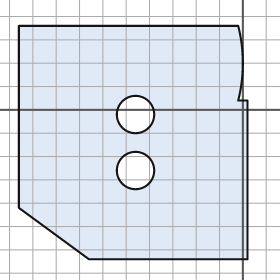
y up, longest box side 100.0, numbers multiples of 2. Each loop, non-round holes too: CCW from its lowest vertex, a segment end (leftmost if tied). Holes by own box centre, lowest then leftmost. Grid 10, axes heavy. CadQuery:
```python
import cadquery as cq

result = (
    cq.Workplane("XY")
    .moveTo(-66.0, -64.0)
    .lineTo(2.0, -64.0)
    .lineTo(2.0, 4.0)
    .lineTo(-2.0, 4.0)
    .threePointArc((0.0, 20.0), (-2.0, 36.0))
    .lineTo(-96.0, 36.0)
    .lineTo(-96.0, -42.0)
    .close()
    .moveTo(-46.0, -26.0)
    .circle(8.0)
    .moveTo(-46.0, -2.0)
    .circle(8.0)
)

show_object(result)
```